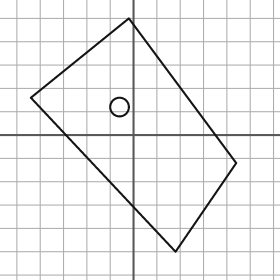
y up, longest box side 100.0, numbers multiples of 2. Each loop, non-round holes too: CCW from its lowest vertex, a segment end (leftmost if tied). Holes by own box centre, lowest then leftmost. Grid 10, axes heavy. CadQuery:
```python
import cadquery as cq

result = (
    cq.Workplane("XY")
    .moveTo(18.0, -50.0)
    .lineTo(44.0, -12.0)
    .lineTo(-2.0, 50.0)
    .lineTo(-44.0, 16.0)
    .close()
    .moveTo(-6.0, 12.0)
    .circle(4.0)
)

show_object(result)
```